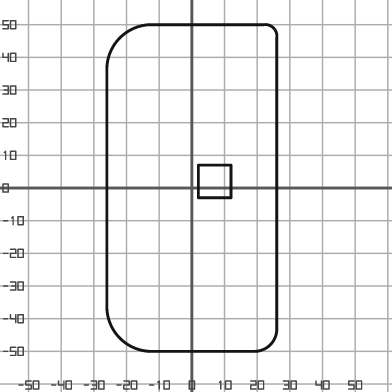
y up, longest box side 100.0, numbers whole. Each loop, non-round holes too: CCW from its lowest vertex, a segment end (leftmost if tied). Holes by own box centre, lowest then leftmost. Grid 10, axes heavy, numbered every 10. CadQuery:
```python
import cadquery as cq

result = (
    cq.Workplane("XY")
    .moveTo(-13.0, -50.0)
    .lineTo(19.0, -50.0)
    .threePointArc((24.0, -48.0), (26.0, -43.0))
    .lineTo(26.0, 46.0)
    .threePointArc((25.0, 49.0), (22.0, 50.0))
    .lineTo(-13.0, 50.0)
    .threePointArc((-22.0, 46.0), (-26.0, 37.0))
    .lineTo(-26.0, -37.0)
    .threePointArc((-22.0, -46.0), (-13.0, -50.0))
    .close()
    .moveTo(2.0, -3.0)
    .lineTo(12.0, -3.0)
    .lineTo(12.0, 7.0)
    .lineTo(2.0, 7.0)
    .close()
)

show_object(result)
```